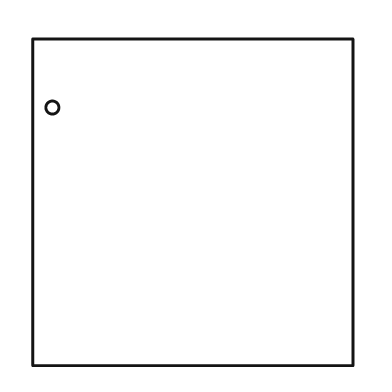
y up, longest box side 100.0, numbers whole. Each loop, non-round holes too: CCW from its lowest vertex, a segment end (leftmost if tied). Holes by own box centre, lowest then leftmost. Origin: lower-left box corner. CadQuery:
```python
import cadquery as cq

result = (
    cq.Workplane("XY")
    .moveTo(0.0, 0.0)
    .lineTo(98.0, 0.0)
    .lineTo(98.0, 100.0)
    .lineTo(0.0, 100.0)
    .close()
    .moveTo(6.0, 79.0)
    .circle(2.0)
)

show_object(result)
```